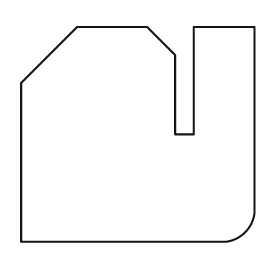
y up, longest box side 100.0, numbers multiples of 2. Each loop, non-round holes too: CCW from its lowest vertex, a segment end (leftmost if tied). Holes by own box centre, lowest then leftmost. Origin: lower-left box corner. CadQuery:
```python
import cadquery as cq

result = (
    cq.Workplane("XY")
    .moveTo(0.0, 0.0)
    .lineTo(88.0, 0.0)
    .threePointArc((96.0, 4.0), (100.0, 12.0))
    .lineTo(100.0, 92.0)
    .lineTo(74.0, 92.0)
    .lineTo(74.0, 46.0)
    .lineTo(66.0, 46.0)
    .lineTo(66.0, 80.0)
    .lineTo(54.0, 92.0)
    .lineTo(24.0, 92.0)
    .lineTo(0.0, 68.0)
    .close()
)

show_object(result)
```